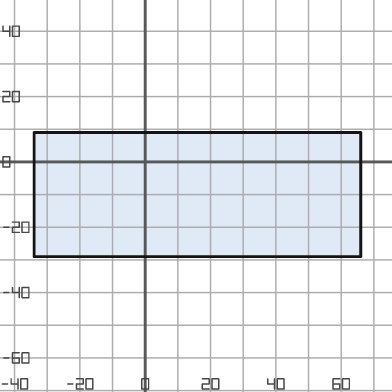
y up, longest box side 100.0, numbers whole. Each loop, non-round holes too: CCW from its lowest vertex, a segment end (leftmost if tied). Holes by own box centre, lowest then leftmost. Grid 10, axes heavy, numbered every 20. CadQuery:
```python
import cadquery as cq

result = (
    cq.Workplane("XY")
    .moveTo(-34.0, -29.0)
    .lineTo(66.0, -29.0)
    .lineTo(66.0, 9.0)
    .lineTo(-34.0, 9.0)
    .close()
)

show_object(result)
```